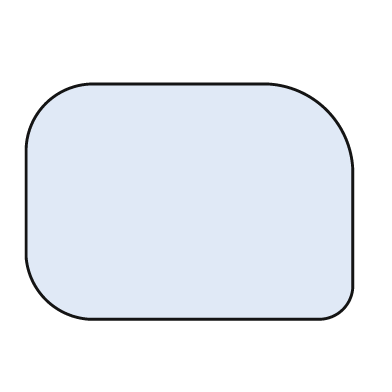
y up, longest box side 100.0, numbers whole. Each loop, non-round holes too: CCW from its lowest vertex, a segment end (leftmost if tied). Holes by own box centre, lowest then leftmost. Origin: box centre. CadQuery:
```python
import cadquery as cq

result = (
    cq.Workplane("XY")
    .moveTo(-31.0, -36.0)
    .lineTo(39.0, -36.0)
    .threePointArc((47.0, -33.0), (50.0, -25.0))
    .lineTo(50.0, 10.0)
    .threePointArc((42.0, 28.0), (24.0, 36.0))
    .lineTo(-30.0, 36.0)
    .threePointArc((-44.0, 30.0), (-50.0, 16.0))
    .lineTo(-50.0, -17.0)
    .threePointArc((-44.0, -30.0), (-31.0, -36.0))
    .close()
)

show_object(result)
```